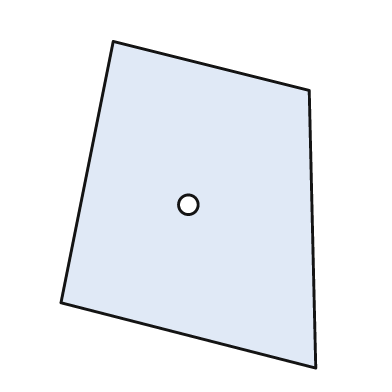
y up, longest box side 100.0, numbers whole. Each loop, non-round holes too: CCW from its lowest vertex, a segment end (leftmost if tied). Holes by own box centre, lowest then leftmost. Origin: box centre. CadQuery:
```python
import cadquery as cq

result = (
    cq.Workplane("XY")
    .moveTo(39.0, -50.0)
    .lineTo(37.0, 35.0)
    .lineTo(-23.0, 50.0)
    .lineTo(-39.0, -30.0)
    .close()
    .moveTo(0.0, 0.0)
    .circle(3.0)
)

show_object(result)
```